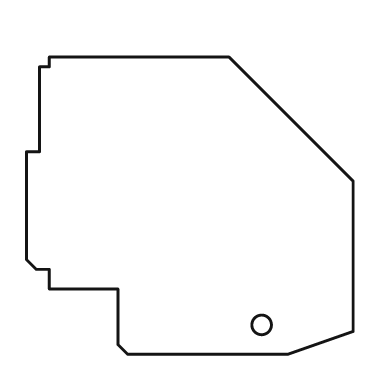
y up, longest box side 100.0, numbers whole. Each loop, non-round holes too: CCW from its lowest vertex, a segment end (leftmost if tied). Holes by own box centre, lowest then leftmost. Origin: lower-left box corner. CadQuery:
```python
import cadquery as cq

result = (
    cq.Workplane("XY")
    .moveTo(31.0, 0.0)
    .lineTo(80.0, 0.0)
    .lineTo(100.0, 7.0)
    .lineTo(100.0, 53.0)
    .lineTo(62.0, 91.0)
    .lineTo(7.0, 91.0)
    .lineTo(7.0, 88.0)
    .lineTo(4.0, 88.0)
    .lineTo(4.0, 62.0)
    .lineTo(0.0, 62.0)
    .lineTo(0.0, 29.0)
    .lineTo(3.0, 26.0)
    .lineTo(7.0, 26.0)
    .lineTo(7.0, 20.0)
    .lineTo(28.0, 20.0)
    .lineTo(28.0, 3.0)
    .close()
    .moveTo(72.0, 9.0)
    .circle(3.0)
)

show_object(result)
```